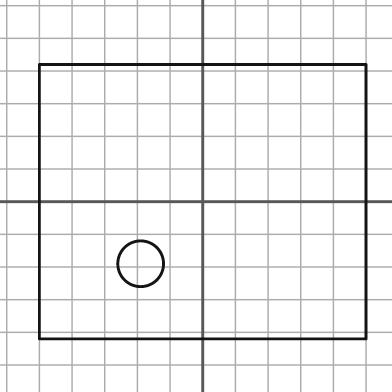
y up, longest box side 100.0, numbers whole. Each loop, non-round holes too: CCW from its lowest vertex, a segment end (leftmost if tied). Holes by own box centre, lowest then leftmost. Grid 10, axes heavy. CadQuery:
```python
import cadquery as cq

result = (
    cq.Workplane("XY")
    .moveTo(-50.0, -42.0)
    .lineTo(50.0, -42.0)
    .lineTo(50.0, 42.0)
    .lineTo(-50.0, 42.0)
    .close()
    .moveTo(-19.0, -19.0)
    .circle(7.0)
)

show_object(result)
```